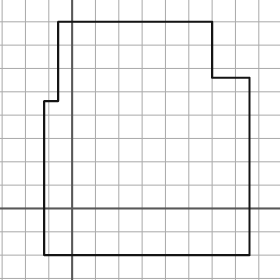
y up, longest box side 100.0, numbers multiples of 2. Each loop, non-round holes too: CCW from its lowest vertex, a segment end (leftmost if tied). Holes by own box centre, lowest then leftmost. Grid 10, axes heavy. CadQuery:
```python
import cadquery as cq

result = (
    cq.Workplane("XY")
    .moveTo(-12.0, -20.0)
    .lineTo(76.0, -20.0)
    .lineTo(76.0, 56.0)
    .lineTo(60.0, 56.0)
    .lineTo(60.0, 80.0)
    .lineTo(-6.0, 80.0)
    .lineTo(-6.0, 46.0)
    .lineTo(-12.0, 46.0)
    .close()
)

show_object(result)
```